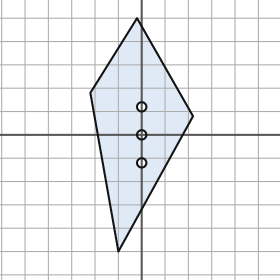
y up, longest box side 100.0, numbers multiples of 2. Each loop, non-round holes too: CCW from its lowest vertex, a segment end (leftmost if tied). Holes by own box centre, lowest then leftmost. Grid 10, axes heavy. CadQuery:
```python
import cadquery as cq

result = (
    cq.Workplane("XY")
    .moveTo(-10.0, -50.0)
    .lineTo(22.0, 8.0)
    .lineTo(-2.0, 50.0)
    .lineTo(-22.0, 18.0)
    .close()
    .moveTo(0.0, -12.0)
    .circle(2.0)
    .moveTo(0.0, 0.0)
    .circle(2.0)
    .moveTo(0.0, 12.0)
    .circle(2.0)
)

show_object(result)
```